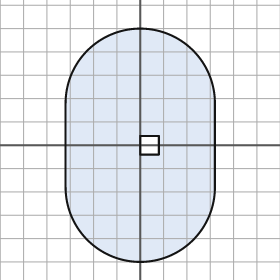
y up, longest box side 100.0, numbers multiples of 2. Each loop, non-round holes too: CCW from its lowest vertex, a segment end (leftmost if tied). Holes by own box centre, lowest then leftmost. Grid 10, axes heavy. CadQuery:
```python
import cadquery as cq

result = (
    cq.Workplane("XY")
    .moveTo(-32.0, -18.0)
    .threePointArc((0.0, -50.0), (32.0, -18.0))
    .lineTo(32.0, 18.0)
    .threePointArc((0.0, 50.0), (-32.0, 18.0))
    .close()
    .moveTo(0.0, -4.0)
    .lineTo(8.0, -4.0)
    .lineTo(8.0, 4.0)
    .lineTo(0.0, 4.0)
    .close()
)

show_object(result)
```